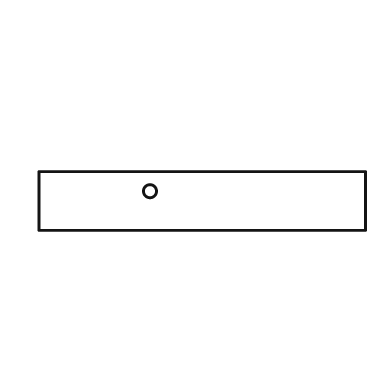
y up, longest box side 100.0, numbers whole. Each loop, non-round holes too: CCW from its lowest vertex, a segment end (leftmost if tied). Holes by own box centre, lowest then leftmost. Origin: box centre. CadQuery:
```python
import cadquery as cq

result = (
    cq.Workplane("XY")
    .moveTo(-50.0, -9.0)
    .lineTo(50.0, -9.0)
    .lineTo(50.0, 9.0)
    .lineTo(-50.0, 9.0)
    .close()
    .moveTo(-16.0, 3.0)
    .circle(2.0)
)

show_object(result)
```